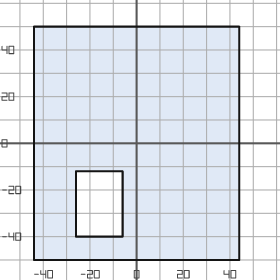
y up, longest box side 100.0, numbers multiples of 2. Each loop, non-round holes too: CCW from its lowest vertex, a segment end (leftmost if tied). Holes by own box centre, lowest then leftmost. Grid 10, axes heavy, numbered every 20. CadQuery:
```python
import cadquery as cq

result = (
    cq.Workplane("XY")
    .moveTo(-44.0, -50.0)
    .lineTo(44.0, -50.0)
    .lineTo(44.0, 50.0)
    .lineTo(-44.0, 50.0)
    .close()
    .moveTo(-26.0, -40.0)
    .lineTo(-6.0, -40.0)
    .lineTo(-6.0, -12.0)
    .lineTo(-26.0, -12.0)
    .close()
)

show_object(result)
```